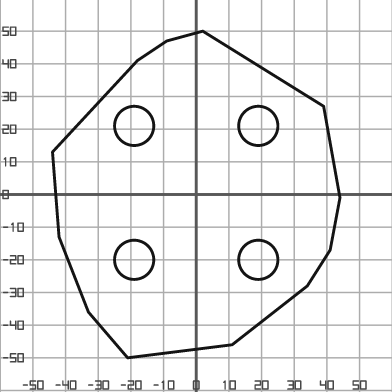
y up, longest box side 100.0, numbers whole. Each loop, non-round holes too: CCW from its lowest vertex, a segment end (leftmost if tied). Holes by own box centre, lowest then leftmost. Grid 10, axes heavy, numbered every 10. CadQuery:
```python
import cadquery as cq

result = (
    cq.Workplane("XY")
    .moveTo(-21.0, -50.0)
    .lineTo(11.0, -46.0)
    .lineTo(34.0, -28.0)
    .lineTo(41.0, -17.0)
    .lineTo(44.0, -1.0)
    .lineTo(39.0, 27.0)
    .lineTo(2.0, 50.0)
    .lineTo(-9.0, 47.0)
    .lineTo(-18.0, 41.0)
    .lineTo(-44.0, 13.0)
    .lineTo(-42.0, -13.0)
    .lineTo(-33.0, -36.0)
    .close()
    .moveTo(-19.0, -20.0)
    .circle(6.0)
    .moveTo(19.0, -20.0)
    .circle(6.0)
    .moveTo(-19.0, 21.0)
    .circle(6.0)
    .moveTo(19.0, 21.0)
    .circle(6.0)
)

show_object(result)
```